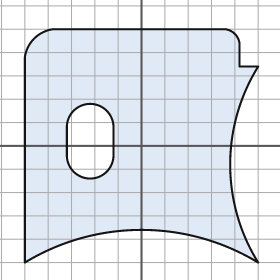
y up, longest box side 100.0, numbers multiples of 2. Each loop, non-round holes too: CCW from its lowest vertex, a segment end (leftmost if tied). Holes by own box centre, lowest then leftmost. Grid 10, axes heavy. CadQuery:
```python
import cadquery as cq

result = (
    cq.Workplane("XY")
    .moveTo(-50.0, -50.0)
    .threePointArc((0.0, -36.0), (50.0, -50.0))
    .threePointArc((38.0, -8.0), (50.0, 34.0))
    .lineTo(42.0, 34.0)
    .lineTo(42.0, 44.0)
    .threePointArc((40.0, 48.0), (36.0, 50.0))
    .lineTo(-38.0, 50.0)
    .threePointArc((-46.0, 46.0), (-50.0, 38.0))
    .close()
    .moveTo(-32.0, -4.0)
    .threePointArc((-22.0, -14.0), (-12.0, -4.0))
    .lineTo(-12.0, 8.0)
    .threePointArc((-22.0, 18.0), (-32.0, 8.0))
    .close()
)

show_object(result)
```